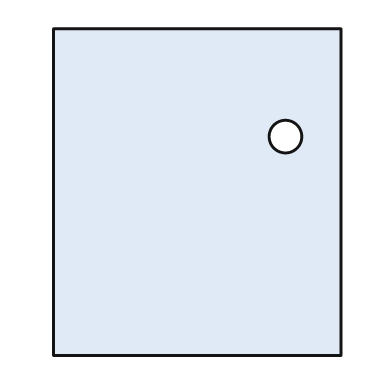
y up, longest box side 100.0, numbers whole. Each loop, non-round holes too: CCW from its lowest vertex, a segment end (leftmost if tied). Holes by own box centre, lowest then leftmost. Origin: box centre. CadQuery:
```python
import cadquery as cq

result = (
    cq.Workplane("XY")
    .moveTo(-44.0, -50.0)
    .lineTo(44.0, -50.0)
    .lineTo(44.0, 50.0)
    .lineTo(-44.0, 50.0)
    .close()
    .moveTo(27.0, 17.0)
    .circle(5.0)
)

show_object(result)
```